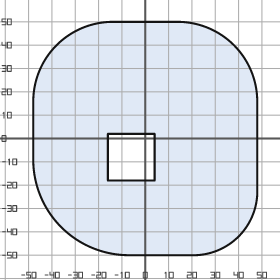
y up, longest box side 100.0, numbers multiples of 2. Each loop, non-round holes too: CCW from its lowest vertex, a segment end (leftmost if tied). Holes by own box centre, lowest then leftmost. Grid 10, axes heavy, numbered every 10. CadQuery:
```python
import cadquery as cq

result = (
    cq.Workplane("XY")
    .moveTo(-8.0, -50.0)
    .lineTo(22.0, -50.0)
    .threePointArc((40.0, -42.0), (48.0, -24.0))
    .lineTo(48.0, 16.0)
    .threePointArc((38.0, 40.0), (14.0, 50.0))
    .lineTo(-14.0, 50.0)
    .threePointArc((-38.0, 40.0), (-48.0, 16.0))
    .lineTo(-48.0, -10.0)
    .threePointArc((-36.0, -38.0), (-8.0, -50.0))
    .close()
    .moveTo(-16.0, -18.0)
    .lineTo(4.0, -18.0)
    .lineTo(4.0, 2.0)
    .lineTo(-16.0, 2.0)
    .close()
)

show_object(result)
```